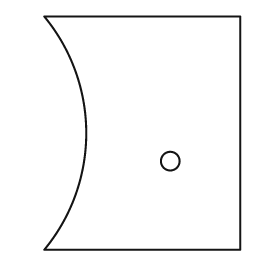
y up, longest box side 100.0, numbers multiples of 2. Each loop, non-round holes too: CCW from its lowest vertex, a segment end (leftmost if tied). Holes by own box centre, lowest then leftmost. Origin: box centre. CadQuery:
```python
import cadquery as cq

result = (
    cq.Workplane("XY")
    .moveTo(-42.0, -50.0)
    .lineTo(42.0, -50.0)
    .lineTo(42.0, 50.0)
    .lineTo(-42.0, 50.0)
    .threePointArc((-24.0, 0.0), (-42.0, -50.0))
    .close()
    .moveTo(12.0, -12.0)
    .circle(4.0)
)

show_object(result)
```